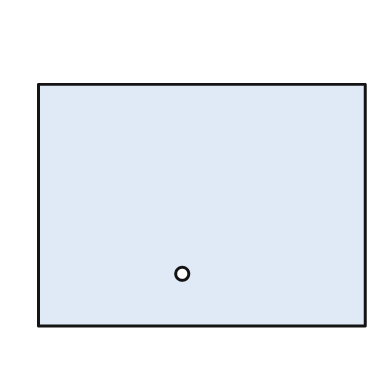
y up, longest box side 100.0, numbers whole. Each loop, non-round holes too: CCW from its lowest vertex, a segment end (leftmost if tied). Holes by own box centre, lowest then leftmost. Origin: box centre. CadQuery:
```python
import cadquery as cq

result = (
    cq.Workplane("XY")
    .moveTo(-50.0, -37.0)
    .lineTo(50.0, -37.0)
    .lineTo(50.0, 37.0)
    .lineTo(-50.0, 37.0)
    .close()
    .moveTo(-6.0, -21.0)
    .circle(2.0)
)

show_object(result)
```